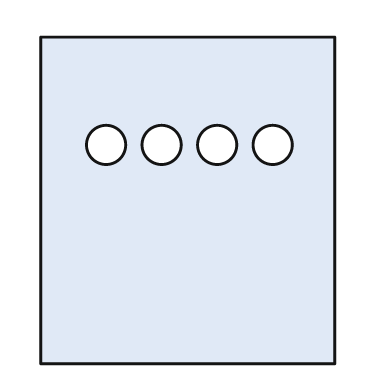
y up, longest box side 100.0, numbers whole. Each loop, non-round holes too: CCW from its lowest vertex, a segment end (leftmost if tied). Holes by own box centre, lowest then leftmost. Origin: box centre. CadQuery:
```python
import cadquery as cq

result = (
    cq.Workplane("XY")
    .moveTo(-45.0, -50.0)
    .lineTo(45.0, -50.0)
    .lineTo(45.0, 50.0)
    .lineTo(-45.0, 50.0)
    .close()
    .moveTo(-25.0, 17.0)
    .circle(6.0)
    .moveTo(-8.0, 17.0)
    .circle(6.0)
    .moveTo(9.0, 17.0)
    .circle(6.0)
    .moveTo(26.0, 17.0)
    .circle(6.0)
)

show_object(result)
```